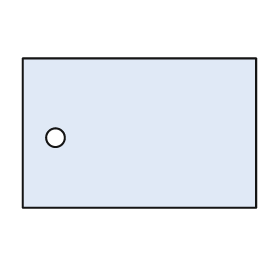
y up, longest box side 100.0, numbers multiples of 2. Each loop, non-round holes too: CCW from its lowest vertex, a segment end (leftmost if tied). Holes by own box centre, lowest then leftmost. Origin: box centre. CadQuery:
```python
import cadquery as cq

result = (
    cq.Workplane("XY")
    .moveTo(-50.0, -32.0)
    .lineTo(50.0, -32.0)
    .lineTo(50.0, 32.0)
    .lineTo(-50.0, 32.0)
    .close()
    .moveTo(-36.0, -2.0)
    .circle(4.0)
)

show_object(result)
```